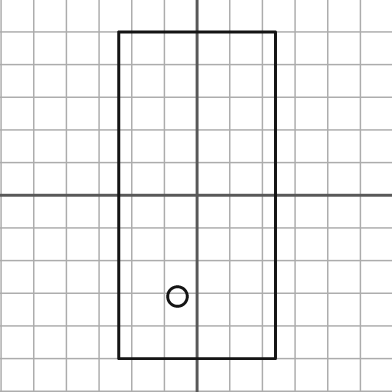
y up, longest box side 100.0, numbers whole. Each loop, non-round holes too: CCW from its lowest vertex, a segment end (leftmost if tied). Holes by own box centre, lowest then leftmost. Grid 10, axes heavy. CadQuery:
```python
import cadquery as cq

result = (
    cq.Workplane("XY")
    .moveTo(-24.0, -50.0)
    .lineTo(24.0, -50.0)
    .lineTo(24.0, 50.0)
    .lineTo(-24.0, 50.0)
    .close()
    .moveTo(-6.0, -31.0)
    .circle(3.0)
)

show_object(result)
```